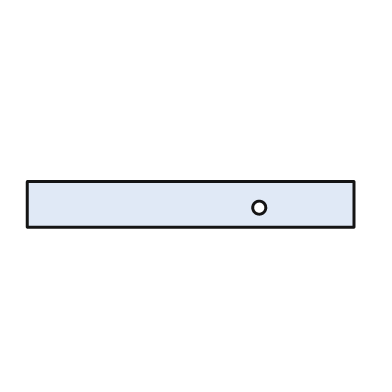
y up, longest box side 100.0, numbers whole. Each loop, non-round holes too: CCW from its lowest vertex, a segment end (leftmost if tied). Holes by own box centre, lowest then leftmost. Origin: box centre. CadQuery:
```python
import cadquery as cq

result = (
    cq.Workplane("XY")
    .moveTo(-50.0, -7.0)
    .lineTo(50.0, -7.0)
    .lineTo(50.0, 7.0)
    .lineTo(-50.0, 7.0)
    .close()
    .moveTo(21.0, -1.0)
    .circle(2.0)
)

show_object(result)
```